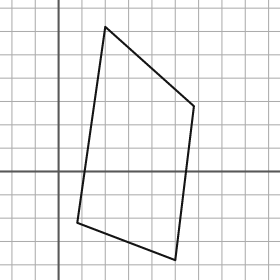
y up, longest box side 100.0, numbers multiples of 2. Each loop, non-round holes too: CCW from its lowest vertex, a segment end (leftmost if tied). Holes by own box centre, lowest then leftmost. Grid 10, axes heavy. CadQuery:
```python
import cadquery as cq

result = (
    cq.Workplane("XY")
    .moveTo(50.0, -38.0)
    .lineTo(58.0, 28.0)
    .lineTo(20.0, 62.0)
    .lineTo(8.0, -22.0)
    .close()
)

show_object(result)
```